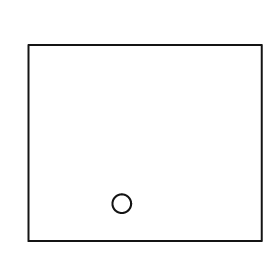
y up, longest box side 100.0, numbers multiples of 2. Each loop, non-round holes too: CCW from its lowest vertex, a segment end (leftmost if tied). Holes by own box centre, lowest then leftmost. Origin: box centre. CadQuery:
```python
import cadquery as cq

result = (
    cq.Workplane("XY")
    .moveTo(-50.0, -42.0)
    .lineTo(50.0, -42.0)
    .lineTo(50.0, 42.0)
    .lineTo(-50.0, 42.0)
    .close()
    .moveTo(-10.0, -26.0)
    .circle(4.0)
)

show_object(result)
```